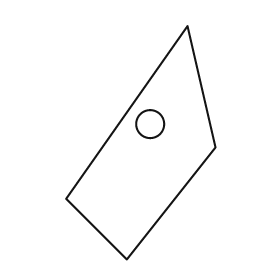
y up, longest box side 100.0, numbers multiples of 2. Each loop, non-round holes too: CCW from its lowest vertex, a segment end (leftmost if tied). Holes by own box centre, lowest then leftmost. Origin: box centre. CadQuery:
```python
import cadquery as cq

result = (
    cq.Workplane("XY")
    .moveTo(-6.0, -50.0)
    .lineTo(32.0, -2.0)
    .lineTo(20.0, 50.0)
    .lineTo(-32.0, -24.0)
    .close()
    .moveTo(4.0, 8.0)
    .circle(6.0)
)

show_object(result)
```